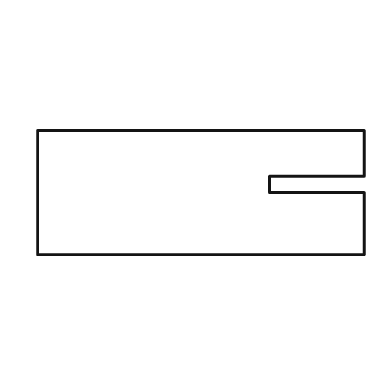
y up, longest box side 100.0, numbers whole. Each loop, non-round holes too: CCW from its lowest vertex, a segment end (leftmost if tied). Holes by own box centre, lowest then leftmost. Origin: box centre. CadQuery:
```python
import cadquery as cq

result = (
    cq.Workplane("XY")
    .moveTo(-50.0, -19.0)
    .lineTo(50.0, -19.0)
    .lineTo(50.0, 0.0)
    .lineTo(21.0, 0.0)
    .lineTo(21.0, 5.0)
    .lineTo(50.0, 5.0)
    .lineTo(50.0, 19.0)
    .lineTo(-50.0, 19.0)
    .close()
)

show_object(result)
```